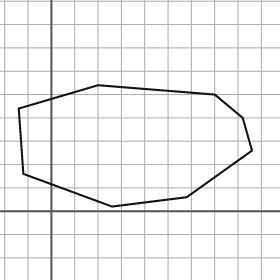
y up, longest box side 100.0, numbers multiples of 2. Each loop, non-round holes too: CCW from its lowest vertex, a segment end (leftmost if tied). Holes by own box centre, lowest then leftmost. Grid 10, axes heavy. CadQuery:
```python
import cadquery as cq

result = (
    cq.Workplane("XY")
    .moveTo(26.0, 2.0)
    .lineTo(58.0, 6.0)
    .lineTo(86.0, 26.0)
    .lineTo(82.0, 40.0)
    .lineTo(70.0, 50.0)
    .lineTo(20.0, 54.0)
    .lineTo(-14.0, 44.0)
    .lineTo(-12.0, 16.0)
    .close()
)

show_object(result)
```